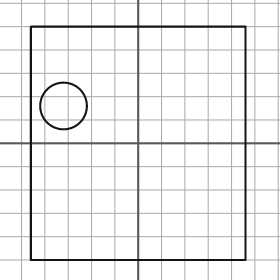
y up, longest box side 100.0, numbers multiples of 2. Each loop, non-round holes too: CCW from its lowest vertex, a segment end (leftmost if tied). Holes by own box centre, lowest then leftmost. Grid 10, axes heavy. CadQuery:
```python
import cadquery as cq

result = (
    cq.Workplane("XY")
    .moveTo(-46.0, -50.0)
    .lineTo(46.0, -50.0)
    .lineTo(46.0, 50.0)
    .lineTo(-46.0, 50.0)
    .close()
    .moveTo(-32.0, 16.0)
    .circle(10.0)
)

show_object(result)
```